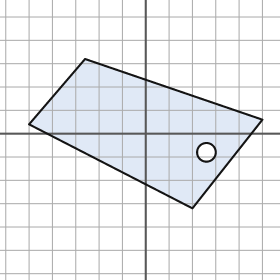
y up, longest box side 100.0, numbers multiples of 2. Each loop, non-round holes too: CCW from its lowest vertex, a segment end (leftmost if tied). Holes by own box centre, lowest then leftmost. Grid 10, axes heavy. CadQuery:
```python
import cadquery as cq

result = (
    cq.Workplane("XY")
    .moveTo(20.0, -32.0)
    .lineTo(50.0, 6.0)
    .lineTo(-26.0, 32.0)
    .lineTo(-50.0, 4.0)
    .close()
    .moveTo(26.0, -8.0)
    .circle(4.0)
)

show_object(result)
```